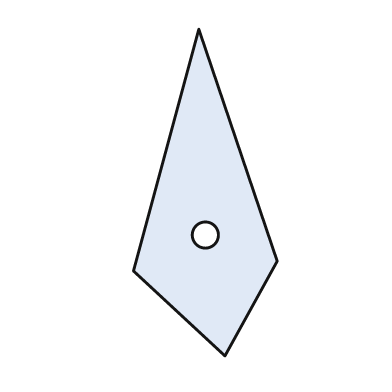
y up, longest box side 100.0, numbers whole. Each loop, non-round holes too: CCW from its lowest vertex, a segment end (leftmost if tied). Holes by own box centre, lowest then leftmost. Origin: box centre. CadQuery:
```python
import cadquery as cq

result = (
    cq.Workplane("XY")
    .moveTo(6.0, -50.0)
    .lineTo(22.0, -21.0)
    .lineTo(-2.0, 50.0)
    .lineTo(-22.0, -24.0)
    .close()
    .moveTo(0.0, -13.0)
    .circle(4.0)
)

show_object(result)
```